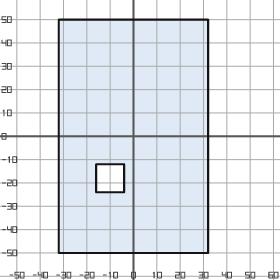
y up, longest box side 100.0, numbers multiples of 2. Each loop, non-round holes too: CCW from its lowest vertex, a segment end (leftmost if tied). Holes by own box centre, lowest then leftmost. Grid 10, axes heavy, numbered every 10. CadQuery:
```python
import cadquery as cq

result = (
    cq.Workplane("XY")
    .moveTo(-32.0, -50.0)
    .lineTo(32.0, -50.0)
    .lineTo(32.0, 50.0)
    .lineTo(-32.0, 50.0)
    .close()
    .moveTo(-16.0, -24.0)
    .lineTo(-4.0, -24.0)
    .lineTo(-4.0, -12.0)
    .lineTo(-16.0, -12.0)
    .close()
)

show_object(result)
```